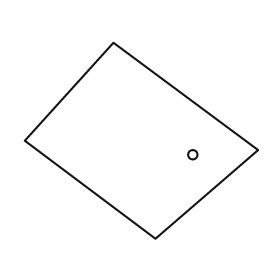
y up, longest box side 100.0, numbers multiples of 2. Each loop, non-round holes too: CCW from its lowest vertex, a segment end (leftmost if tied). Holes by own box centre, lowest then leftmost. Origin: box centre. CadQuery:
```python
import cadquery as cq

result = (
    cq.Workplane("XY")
    .moveTo(6.0, -42.0)
    .lineTo(50.0, -4.0)
    .lineTo(-12.0, 42.0)
    .lineTo(-50.0, 0.0)
    .close()
    .moveTo(22.0, -6.0)
    .circle(2.0)
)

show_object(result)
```